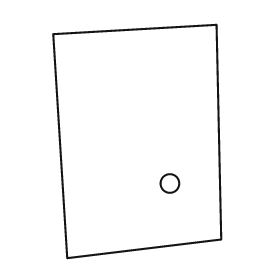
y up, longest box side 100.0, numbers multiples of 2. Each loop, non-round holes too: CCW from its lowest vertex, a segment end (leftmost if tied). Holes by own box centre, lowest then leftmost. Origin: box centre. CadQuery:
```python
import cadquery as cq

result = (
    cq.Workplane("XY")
    .moveTo(-30.0, -50.0)
    .lineTo(36.0, -42.0)
    .lineTo(34.0, 50.0)
    .lineTo(-36.0, 46.0)
    .close()
    .moveTo(14.0, -18.0)
    .circle(4.0)
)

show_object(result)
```